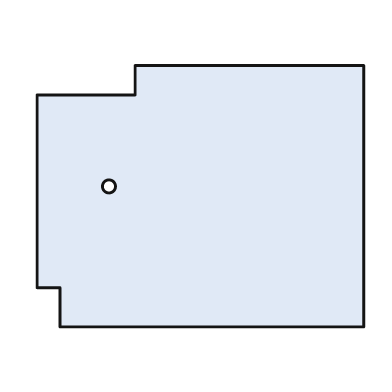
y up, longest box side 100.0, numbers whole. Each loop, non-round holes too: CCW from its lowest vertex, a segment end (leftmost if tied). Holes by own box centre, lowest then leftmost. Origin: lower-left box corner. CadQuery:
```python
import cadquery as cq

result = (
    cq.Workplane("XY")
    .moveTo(7.0, 0.0)
    .lineTo(100.0, 0.0)
    .lineTo(100.0, 80.0)
    .lineTo(30.0, 80.0)
    .lineTo(30.0, 71.0)
    .lineTo(0.0, 71.0)
    .lineTo(0.0, 12.0)
    .lineTo(7.0, 12.0)
    .close()
    .moveTo(22.0, 43.0)
    .circle(2.0)
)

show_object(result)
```